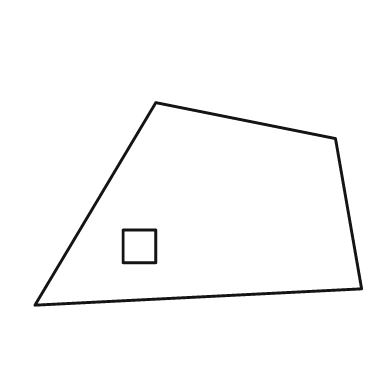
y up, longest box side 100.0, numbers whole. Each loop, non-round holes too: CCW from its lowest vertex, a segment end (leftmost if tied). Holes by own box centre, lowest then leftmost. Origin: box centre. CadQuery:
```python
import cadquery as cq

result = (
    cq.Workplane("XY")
    .moveTo(-50.0, -31.0)
    .lineTo(50.0, -26.0)
    .lineTo(42.0, 20.0)
    .lineTo(-13.0, 31.0)
    .close()
    .moveTo(-23.0, -18.0)
    .lineTo(-13.0, -18.0)
    .lineTo(-13.0, -8.0)
    .lineTo(-23.0, -8.0)
    .close()
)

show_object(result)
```